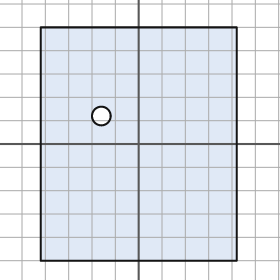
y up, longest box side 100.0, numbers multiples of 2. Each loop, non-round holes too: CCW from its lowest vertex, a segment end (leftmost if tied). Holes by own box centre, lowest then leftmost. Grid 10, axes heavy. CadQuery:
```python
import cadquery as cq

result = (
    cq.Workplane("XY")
    .moveTo(-42.0, -50.0)
    .lineTo(42.0, -50.0)
    .lineTo(42.0, 50.0)
    .lineTo(-42.0, 50.0)
    .close()
    .moveTo(-16.0, 12.0)
    .circle(4.0)
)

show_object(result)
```